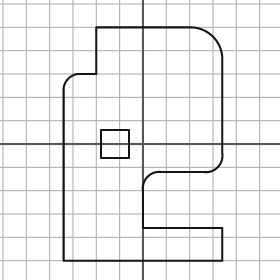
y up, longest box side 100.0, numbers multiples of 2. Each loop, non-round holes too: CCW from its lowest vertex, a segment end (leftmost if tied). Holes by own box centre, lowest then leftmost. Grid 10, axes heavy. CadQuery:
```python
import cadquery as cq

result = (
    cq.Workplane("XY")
    .moveTo(-34.0, -50.0)
    .lineTo(34.0, -50.0)
    .lineTo(34.0, -36.0)
    .lineTo(0.0, -36.0)
    .lineTo(0.0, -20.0)
    .threePointArc((2.0, -14.0), (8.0, -12.0))
    .lineTo(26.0, -12.0)
    .threePointArc((32.0, -10.0), (34.0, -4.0))
    .lineTo(34.0, 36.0)
    .threePointArc((30.0, 46.0), (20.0, 50.0))
    .lineTo(-20.0, 50.0)
    .lineTo(-20.0, 30.0)
    .lineTo(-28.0, 30.0)
    .threePointArc((-32.0, 28.0), (-34.0, 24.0))
    .close()
    .moveTo(-18.0, -6.0)
    .lineTo(-6.0, -6.0)
    .lineTo(-6.0, 6.0)
    .lineTo(-18.0, 6.0)
    .close()
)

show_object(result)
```